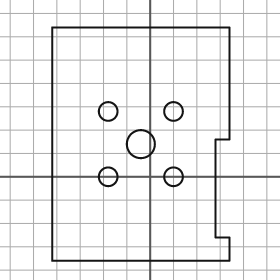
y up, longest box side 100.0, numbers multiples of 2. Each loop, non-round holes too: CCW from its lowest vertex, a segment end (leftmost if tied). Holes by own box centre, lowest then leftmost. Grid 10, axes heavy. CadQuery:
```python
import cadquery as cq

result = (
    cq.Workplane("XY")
    .moveTo(-42.0, -36.0)
    .lineTo(34.0, -36.0)
    .lineTo(34.0, -26.0)
    .lineTo(28.0, -26.0)
    .lineTo(28.0, 16.0)
    .lineTo(34.0, 16.0)
    .lineTo(34.0, 64.0)
    .lineTo(-42.0, 64.0)
    .close()
    .moveTo(-18.0, 0.0)
    .circle(4.0)
    .moveTo(10.0, 0.0)
    .circle(4.0)
    .moveTo(-4.0, 14.0)
    .circle(6.0)
    .moveTo(-18.0, 28.0)
    .circle(4.0)
    .moveTo(10.0, 28.0)
    .circle(4.0)
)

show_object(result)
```